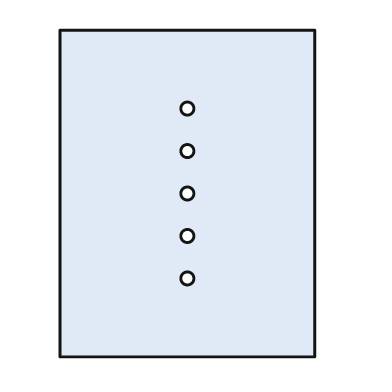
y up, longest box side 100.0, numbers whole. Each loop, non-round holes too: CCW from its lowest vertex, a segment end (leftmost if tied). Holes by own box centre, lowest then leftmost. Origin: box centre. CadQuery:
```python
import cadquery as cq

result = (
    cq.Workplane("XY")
    .moveTo(-39.0, -50.0)
    .lineTo(39.0, -50.0)
    .lineTo(39.0, 50.0)
    .lineTo(-39.0, 50.0)
    .close()
    .moveTo(0.0, -26.0)
    .circle(2.0)
    .moveTo(0.0, -13.0)
    .circle(2.0)
    .moveTo(0.0, 0.0)
    .circle(2.0)
    .moveTo(0.0, 13.0)
    .circle(2.0)
    .moveTo(0.0, 26.0)
    .circle(2.0)
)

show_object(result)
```